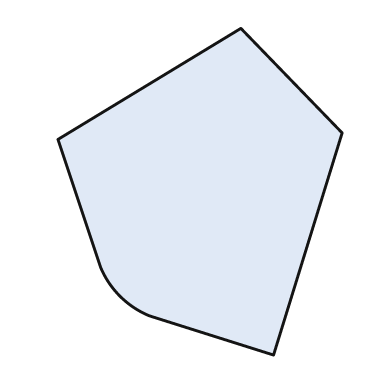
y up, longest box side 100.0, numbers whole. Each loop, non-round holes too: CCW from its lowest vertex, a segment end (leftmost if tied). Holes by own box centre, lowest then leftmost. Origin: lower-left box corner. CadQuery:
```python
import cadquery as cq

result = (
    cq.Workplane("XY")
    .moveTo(66.0, 0.0)
    .lineTo(87.0, 68.0)
    .lineTo(56.0, 100.0)
    .lineTo(0.0, 66.0)
    .lineTo(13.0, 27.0)
    .threePointArc((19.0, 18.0), (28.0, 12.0))
    .close()
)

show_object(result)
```